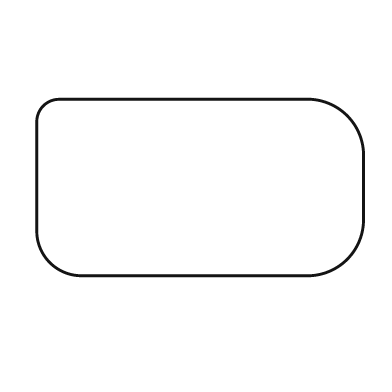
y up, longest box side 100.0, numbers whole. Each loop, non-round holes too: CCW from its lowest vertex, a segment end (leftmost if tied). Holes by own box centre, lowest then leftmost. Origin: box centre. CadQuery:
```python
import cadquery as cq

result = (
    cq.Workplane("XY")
    .moveTo(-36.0, -27.0)
    .lineTo(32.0, -27.0)
    .threePointArc((45.0, -22.0), (50.0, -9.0))
    .lineTo(50.0, 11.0)
    .threePointArc((45.0, 22.0), (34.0, 27.0))
    .lineTo(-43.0, 27.0)
    .threePointArc((-48.0, 25.0), (-50.0, 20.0))
    .lineTo(-50.0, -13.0)
    .threePointArc((-46.0, -23.0), (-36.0, -27.0))
    .close()
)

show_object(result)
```